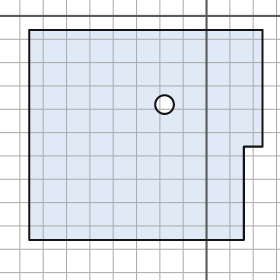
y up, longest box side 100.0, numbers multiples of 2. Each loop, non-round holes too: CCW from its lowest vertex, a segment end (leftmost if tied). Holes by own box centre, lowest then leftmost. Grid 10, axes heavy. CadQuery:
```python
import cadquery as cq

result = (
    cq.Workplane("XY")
    .moveTo(-76.0, -96.0)
    .lineTo(16.0, -96.0)
    .lineTo(16.0, -56.0)
    .lineTo(24.0, -56.0)
    .lineTo(24.0, -6.0)
    .lineTo(-76.0, -6.0)
    .close()
    .moveTo(-18.0, -38.0)
    .circle(4.0)
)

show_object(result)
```